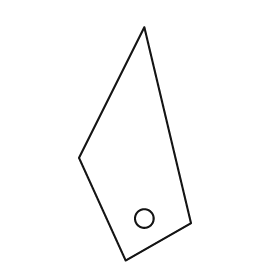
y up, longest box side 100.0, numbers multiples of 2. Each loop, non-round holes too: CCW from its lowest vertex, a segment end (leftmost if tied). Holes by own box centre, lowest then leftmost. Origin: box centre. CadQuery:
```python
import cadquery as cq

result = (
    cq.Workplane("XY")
    .moveTo(-4.0, -50.0)
    .lineTo(24.0, -34.0)
    .lineTo(4.0, 50.0)
    .lineTo(-24.0, -6.0)
    .close()
    .moveTo(4.0, -32.0)
    .circle(4.0)
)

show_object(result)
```